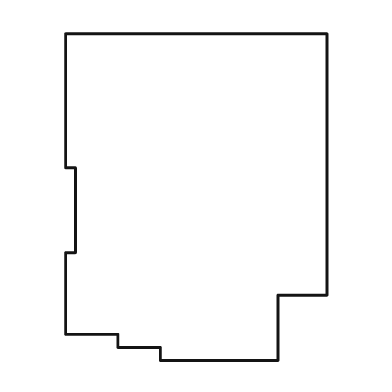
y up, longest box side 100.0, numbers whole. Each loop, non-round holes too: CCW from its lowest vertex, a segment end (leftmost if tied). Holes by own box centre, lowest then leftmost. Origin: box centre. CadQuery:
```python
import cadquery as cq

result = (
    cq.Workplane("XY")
    .moveTo(-11.0, -50.0)
    .lineTo(25.0, -50.0)
    .lineTo(25.0, -30.0)
    .lineTo(40.0, -30.0)
    .lineTo(40.0, 50.0)
    .lineTo(-40.0, 50.0)
    .lineTo(-40.0, 9.0)
    .lineTo(-37.0, 9.0)
    .lineTo(-37.0, -17.0)
    .lineTo(-40.0, -17.0)
    .lineTo(-40.0, -42.0)
    .lineTo(-24.0, -42.0)
    .lineTo(-24.0, -46.0)
    .lineTo(-11.0, -46.0)
    .close()
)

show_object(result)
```